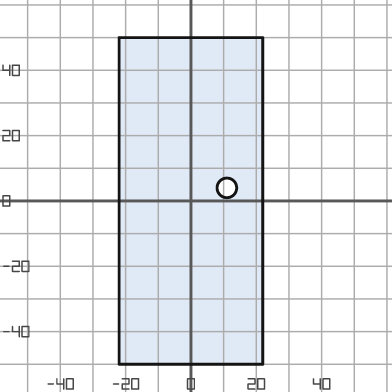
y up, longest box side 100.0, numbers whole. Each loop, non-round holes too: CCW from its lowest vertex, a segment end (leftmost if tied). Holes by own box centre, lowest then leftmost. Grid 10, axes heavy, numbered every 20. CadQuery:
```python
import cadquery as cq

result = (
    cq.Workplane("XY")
    .moveTo(-22.0, -50.0)
    .lineTo(22.0, -50.0)
    .lineTo(22.0, 50.0)
    .lineTo(-22.0, 50.0)
    .close()
    .moveTo(11.0, 4.0)
    .circle(3.0)
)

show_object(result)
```